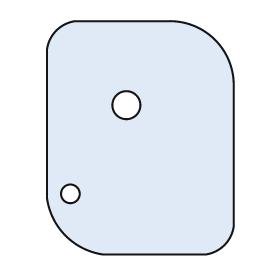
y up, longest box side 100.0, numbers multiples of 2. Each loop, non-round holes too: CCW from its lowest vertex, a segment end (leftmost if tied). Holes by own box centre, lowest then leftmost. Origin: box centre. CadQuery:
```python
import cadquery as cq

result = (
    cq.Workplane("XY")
    .moveTo(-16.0, -50.0)
    .lineTo(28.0, -50.0)
    .threePointArc((36.0, -46.0), (40.0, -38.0))
    .lineTo(40.0, 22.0)
    .threePointArc((32.0, 42.0), (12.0, 50.0))
    .lineTo(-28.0, 50.0)
    .threePointArc((-36.0, 46.0), (-40.0, 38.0))
    .lineTo(-40.0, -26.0)
    .threePointArc((-32.0, -42.0), (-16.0, -50.0))
    .close()
    .moveTo(-30.0, -24.0)
    .circle(4.0)
    .moveTo(-6.0, 14.0)
    .circle(6.0)
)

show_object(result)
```